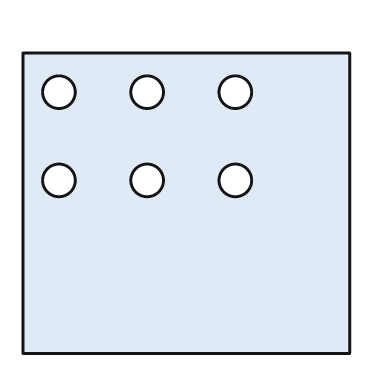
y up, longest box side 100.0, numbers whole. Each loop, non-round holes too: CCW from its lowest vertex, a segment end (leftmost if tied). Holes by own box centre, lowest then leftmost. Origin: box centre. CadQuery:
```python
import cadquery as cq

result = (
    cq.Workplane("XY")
    .moveTo(-50.0, -46.0)
    .lineTo(50.0, -46.0)
    .lineTo(50.0, 46.0)
    .lineTo(-50.0, 46.0)
    .close()
    .moveTo(-39.0, 7.0)
    .circle(5.0)
    .moveTo(-12.0, 7.0)
    .circle(5.0)
    .moveTo(15.0, 7.0)
    .circle(5.0)
    .moveTo(-39.0, 34.0)
    .circle(5.0)
    .moveTo(-12.0, 34.0)
    .circle(5.0)
    .moveTo(15.0, 34.0)
    .circle(5.0)
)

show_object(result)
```